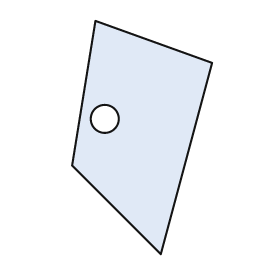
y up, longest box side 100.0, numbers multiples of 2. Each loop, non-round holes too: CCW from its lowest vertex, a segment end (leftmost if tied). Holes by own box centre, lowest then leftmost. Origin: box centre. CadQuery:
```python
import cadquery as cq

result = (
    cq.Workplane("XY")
    .moveTo(8.0, -50.0)
    .lineTo(30.0, 32.0)
    .lineTo(-20.0, 50.0)
    .lineTo(-30.0, -12.0)
    .close()
    .moveTo(-16.0, 8.0)
    .circle(6.0)
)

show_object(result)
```